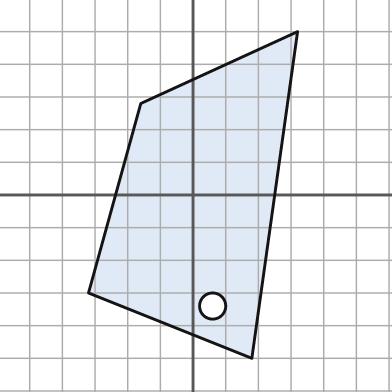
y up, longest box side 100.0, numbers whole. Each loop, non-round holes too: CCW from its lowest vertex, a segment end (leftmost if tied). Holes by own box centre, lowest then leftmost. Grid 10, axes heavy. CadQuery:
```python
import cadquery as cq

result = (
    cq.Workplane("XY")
    .moveTo(18.0, -50.0)
    .lineTo(32.0, 50.0)
    .lineTo(-16.0, 28.0)
    .lineTo(-32.0, -30.0)
    .close()
    .moveTo(6.0, -34.0)
    .circle(4.0)
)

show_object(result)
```